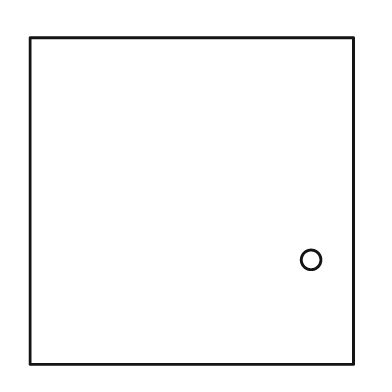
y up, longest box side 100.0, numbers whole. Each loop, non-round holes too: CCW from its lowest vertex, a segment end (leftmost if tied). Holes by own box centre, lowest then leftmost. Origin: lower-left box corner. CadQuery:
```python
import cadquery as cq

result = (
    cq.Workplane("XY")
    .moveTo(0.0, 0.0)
    .lineTo(99.0, 0.0)
    .lineTo(99.0, 100.0)
    .lineTo(0.0, 100.0)
    .close()
    .moveTo(86.0, 32.0)
    .circle(3.0)
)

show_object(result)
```